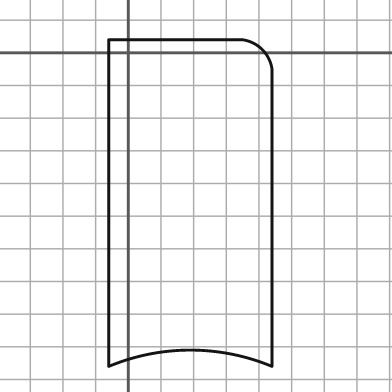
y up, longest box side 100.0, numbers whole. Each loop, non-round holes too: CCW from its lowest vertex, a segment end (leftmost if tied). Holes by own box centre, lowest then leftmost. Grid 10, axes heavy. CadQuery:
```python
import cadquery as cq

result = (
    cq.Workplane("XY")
    .moveTo(-6.0, -96.0)
    .threePointArc((19.0, -91.0), (44.0, -96.0))
    .lineTo(44.0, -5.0)
    .threePointArc((41.0, 1.0), (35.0, 4.0))
    .lineTo(-6.0, 4.0)
    .close()
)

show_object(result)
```